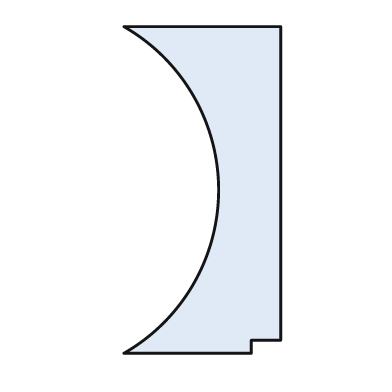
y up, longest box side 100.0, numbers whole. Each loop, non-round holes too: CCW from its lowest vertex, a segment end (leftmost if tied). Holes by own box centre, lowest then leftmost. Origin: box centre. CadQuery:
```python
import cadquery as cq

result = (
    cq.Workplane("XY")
    .moveTo(-24.0, -50.0)
    .lineTo(15.0, -50.0)
    .lineTo(15.0, -46.0)
    .lineTo(24.0, -46.0)
    .lineTo(24.0, 50.0)
    .lineTo(-24.0, 50.0)
    .threePointArc((5.0, 0.0), (-24.0, -50.0))
    .close()
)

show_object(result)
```